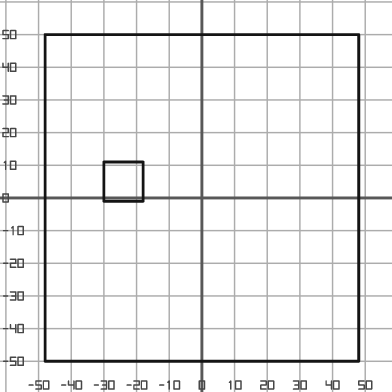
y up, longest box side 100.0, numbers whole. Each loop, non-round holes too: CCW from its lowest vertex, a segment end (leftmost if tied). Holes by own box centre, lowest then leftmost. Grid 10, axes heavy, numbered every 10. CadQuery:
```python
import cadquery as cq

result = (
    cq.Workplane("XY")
    .moveTo(-48.0, -50.0)
    .lineTo(48.0, -50.0)
    .lineTo(48.0, 50.0)
    .lineTo(-48.0, 50.0)
    .close()
    .moveTo(-30.0, -1.0)
    .lineTo(-18.0, -1.0)
    .lineTo(-18.0, 11.0)
    .lineTo(-30.0, 11.0)
    .close()
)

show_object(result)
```